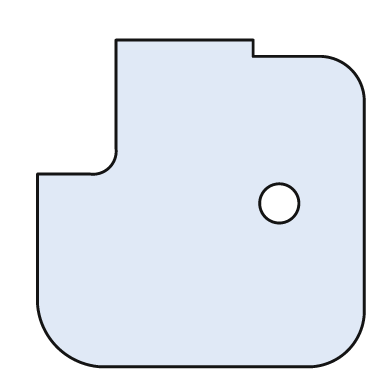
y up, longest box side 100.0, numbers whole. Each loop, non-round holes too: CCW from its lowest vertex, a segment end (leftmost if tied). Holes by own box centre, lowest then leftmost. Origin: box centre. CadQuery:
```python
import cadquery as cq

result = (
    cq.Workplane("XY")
    .moveTo(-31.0, -50.0)
    .lineTo(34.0, -50.0)
    .threePointArc((45.0, -45.0), (50.0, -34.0))
    .lineTo(50.0, 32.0)
    .threePointArc((46.0, 41.0), (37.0, 45.0))
    .lineTo(16.0, 45.0)
    .lineTo(16.0, 50.0)
    .lineTo(-26.0, 50.0)
    .lineTo(-26.0, 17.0)
    .threePointArc((-28.0, 11.0), (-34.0, 9.0))
    .lineTo(-50.0, 9.0)
    .lineTo(-50.0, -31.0)
    .threePointArc((-44.0, -44.0), (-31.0, -50.0))
    .close()
    .moveTo(24.0, 0.0)
    .circle(6.0)
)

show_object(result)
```